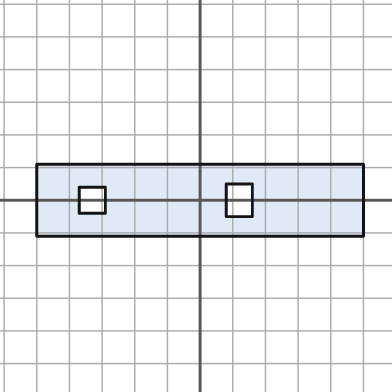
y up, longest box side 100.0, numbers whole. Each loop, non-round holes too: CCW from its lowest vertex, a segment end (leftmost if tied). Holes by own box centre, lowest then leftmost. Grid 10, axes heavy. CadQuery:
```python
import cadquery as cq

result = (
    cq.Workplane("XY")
    .moveTo(-50.0, -11.0)
    .lineTo(50.0, -11.0)
    .lineTo(50.0, 11.0)
    .lineTo(-50.0, 11.0)
    .close()
    .moveTo(-37.0, -4.0)
    .lineTo(-29.0, -4.0)
    .lineTo(-29.0, 4.0)
    .lineTo(-37.0, 4.0)
    .close()
    .moveTo(8.0, -5.0)
    .lineTo(16.0, -5.0)
    .lineTo(16.0, 5.0)
    .lineTo(8.0, 5.0)
    .close()
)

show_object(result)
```